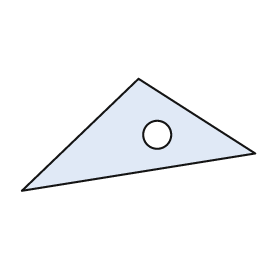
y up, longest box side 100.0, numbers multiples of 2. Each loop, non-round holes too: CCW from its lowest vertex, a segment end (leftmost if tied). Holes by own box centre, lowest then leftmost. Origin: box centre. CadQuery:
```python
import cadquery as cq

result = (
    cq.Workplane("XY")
    .moveTo(-50.0, -24.0)
    .lineTo(50.0, -8.0)
    .lineTo(0.0, 24.0)
    .close()
    .moveTo(8.0, 0.0)
    .circle(6.0)
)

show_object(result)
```